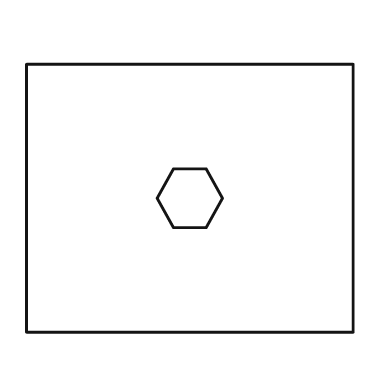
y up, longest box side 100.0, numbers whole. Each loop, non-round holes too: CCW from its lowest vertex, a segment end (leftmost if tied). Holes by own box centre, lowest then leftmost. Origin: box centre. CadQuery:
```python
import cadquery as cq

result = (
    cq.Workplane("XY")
    .moveTo(-50.0, -41.0)
    .lineTo(50.0, -41.0)
    .lineTo(50.0, 41.0)
    .lineTo(-50.0, 41.0)
    .close()
    .moveTo(-5.0, -9.0)
    .lineTo(5.0, -9.0)
    .lineTo(10.0, 0.0)
    .lineTo(5.0, 9.0)
    .lineTo(-5.0, 9.0)
    .lineTo(-10.0, 0.0)
    .close()
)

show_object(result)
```